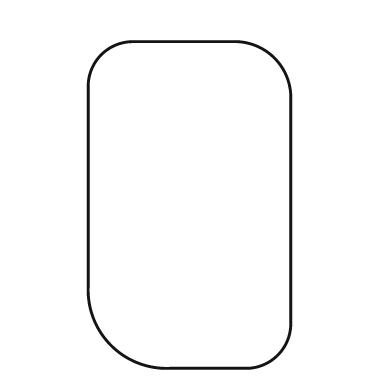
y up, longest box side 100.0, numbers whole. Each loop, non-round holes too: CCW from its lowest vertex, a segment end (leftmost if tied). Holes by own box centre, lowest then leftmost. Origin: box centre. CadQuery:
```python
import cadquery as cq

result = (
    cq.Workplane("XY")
    .moveTo(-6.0, -50.0)
    .lineTo(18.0, -50.0)
    .threePointArc((27.0, -46.0), (31.0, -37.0))
    .lineTo(31.0, 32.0)
    .threePointArc((26.0, 45.0), (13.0, 50.0))
    .lineTo(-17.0, 50.0)
    .threePointArc((-27.0, 46.0), (-31.0, 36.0))
    .lineTo(-31.0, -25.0)
    .threePointArc((-24.0, -43.0), (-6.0, -50.0))
    .close()
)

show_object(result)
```